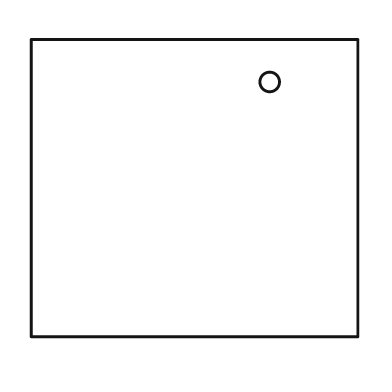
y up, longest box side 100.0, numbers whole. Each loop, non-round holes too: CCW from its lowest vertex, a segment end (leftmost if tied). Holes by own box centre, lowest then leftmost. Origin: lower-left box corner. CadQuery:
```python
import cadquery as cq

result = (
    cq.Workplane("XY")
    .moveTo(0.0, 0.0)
    .lineTo(100.0, 0.0)
    .lineTo(100.0, 91.0)
    .lineTo(0.0, 91.0)
    .close()
    .moveTo(73.0, 78.0)
    .circle(3.0)
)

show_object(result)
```